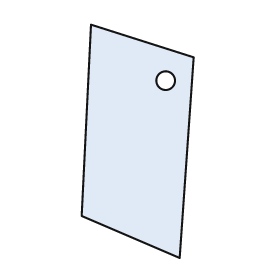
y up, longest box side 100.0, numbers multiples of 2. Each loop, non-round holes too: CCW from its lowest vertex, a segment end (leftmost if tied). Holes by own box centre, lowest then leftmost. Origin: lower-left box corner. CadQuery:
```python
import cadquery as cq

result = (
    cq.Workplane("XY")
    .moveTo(42.0, 0.0)
    .lineTo(48.0, 86.0)
    .lineTo(4.0, 100.0)
    .lineTo(0.0, 18.0)
    .close()
    .moveTo(36.0, 76.0)
    .circle(4.0)
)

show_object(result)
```